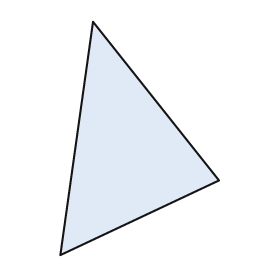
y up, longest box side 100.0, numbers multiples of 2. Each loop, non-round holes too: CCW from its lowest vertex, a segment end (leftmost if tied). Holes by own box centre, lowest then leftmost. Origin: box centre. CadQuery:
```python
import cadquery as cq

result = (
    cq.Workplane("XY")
    .moveTo(-34.0, -50.0)
    .lineTo(34.0, -18.0)
    .lineTo(-20.0, 50.0)
    .close()
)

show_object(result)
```